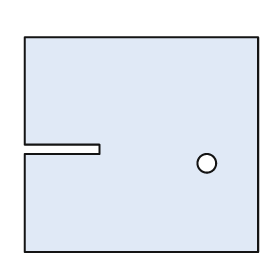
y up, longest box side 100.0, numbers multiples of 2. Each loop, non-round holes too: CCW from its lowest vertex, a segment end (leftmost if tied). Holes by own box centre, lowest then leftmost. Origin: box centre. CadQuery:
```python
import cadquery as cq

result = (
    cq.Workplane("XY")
    .moveTo(-50.0, -46.0)
    .lineTo(50.0, -46.0)
    .lineTo(50.0, 46.0)
    .lineTo(-50.0, 46.0)
    .lineTo(-50.0, 0.0)
    .lineTo(-18.0, 0.0)
    .lineTo(-18.0, -4.0)
    .lineTo(-50.0, -4.0)
    .close()
    .moveTo(28.0, -8.0)
    .circle(4.0)
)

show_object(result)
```